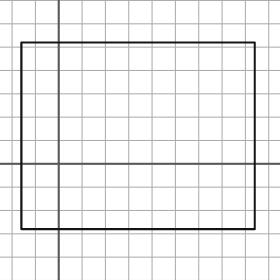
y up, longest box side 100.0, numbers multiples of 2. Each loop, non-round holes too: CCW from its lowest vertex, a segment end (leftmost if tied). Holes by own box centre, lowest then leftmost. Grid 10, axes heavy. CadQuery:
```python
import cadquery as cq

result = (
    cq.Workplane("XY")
    .moveTo(-16.0, -28.0)
    .lineTo(84.0, -28.0)
    .lineTo(84.0, 52.0)
    .lineTo(-16.0, 52.0)
    .close()
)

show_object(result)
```